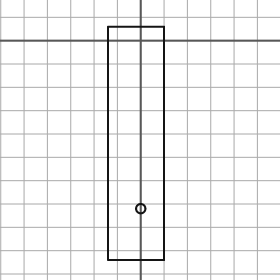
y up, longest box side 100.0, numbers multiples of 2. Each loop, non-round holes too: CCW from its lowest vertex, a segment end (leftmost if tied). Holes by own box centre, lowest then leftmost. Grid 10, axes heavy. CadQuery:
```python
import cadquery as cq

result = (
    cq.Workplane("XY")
    .moveTo(-14.0, -94.0)
    .lineTo(10.0, -94.0)
    .lineTo(10.0, 6.0)
    .lineTo(-14.0, 6.0)
    .close()
    .moveTo(0.0, -72.0)
    .circle(2.0)
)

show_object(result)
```